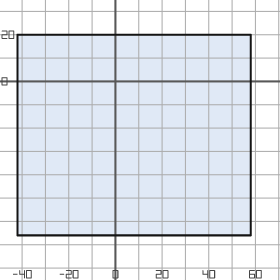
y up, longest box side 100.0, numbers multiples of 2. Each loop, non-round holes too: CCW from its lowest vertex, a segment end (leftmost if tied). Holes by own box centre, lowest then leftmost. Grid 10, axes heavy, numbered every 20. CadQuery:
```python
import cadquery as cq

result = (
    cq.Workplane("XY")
    .moveTo(-42.0, -66.0)
    .lineTo(58.0, -66.0)
    .lineTo(58.0, 20.0)
    .lineTo(-42.0, 20.0)
    .close()
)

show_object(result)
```